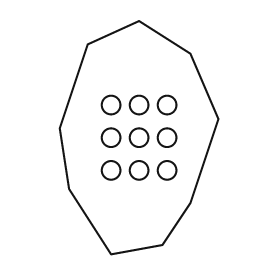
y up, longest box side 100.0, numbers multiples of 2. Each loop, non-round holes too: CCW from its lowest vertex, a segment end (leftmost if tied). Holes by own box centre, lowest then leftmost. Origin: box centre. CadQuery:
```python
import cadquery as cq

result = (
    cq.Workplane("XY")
    .moveTo(-12.0, -50.0)
    .lineTo(10.0, -46.0)
    .lineTo(22.0, -28.0)
    .lineTo(34.0, 8.0)
    .lineTo(22.0, 36.0)
    .lineTo(0.0, 50.0)
    .lineTo(-22.0, 40.0)
    .lineTo(-34.0, 4.0)
    .lineTo(-30.0, -22.0)
    .close()
    .moveTo(-12.0, -14.0)
    .circle(4.0)
    .moveTo(0.0, -14.0)
    .circle(4.0)
    .moveTo(12.0, -14.0)
    .circle(4.0)
    .moveTo(-12.0, 0.0)
    .circle(4.0)
    .moveTo(0.0, 0.0)
    .circle(4.0)
    .moveTo(12.0, 0.0)
    .circle(4.0)
    .moveTo(-12.0, 14.0)
    .circle(4.0)
    .moveTo(0.0, 14.0)
    .circle(4.0)
    .moveTo(12.0, 14.0)
    .circle(4.0)
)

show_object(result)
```